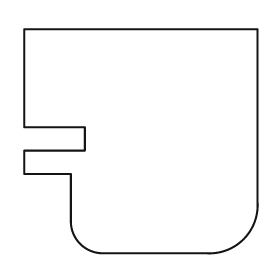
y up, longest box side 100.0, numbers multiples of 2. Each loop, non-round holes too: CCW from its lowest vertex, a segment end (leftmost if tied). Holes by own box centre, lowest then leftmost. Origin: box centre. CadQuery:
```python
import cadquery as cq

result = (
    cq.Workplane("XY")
    .moveTo(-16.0, -48.0)
    .lineTo(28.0, -48.0)
    .threePointArc((44.0, -42.0), (50.0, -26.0))
    .lineTo(50.0, 48.0)
    .lineTo(-50.0, 48.0)
    .lineTo(-50.0, 6.0)
    .lineTo(-24.0, 6.0)
    .lineTo(-24.0, -4.0)
    .lineTo(-50.0, -4.0)
    .lineTo(-50.0, -14.0)
    .lineTo(-30.0, -14.0)
    .lineTo(-30.0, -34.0)
    .threePointArc((-26.0, -44.0), (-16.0, -48.0))
    .close()
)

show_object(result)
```